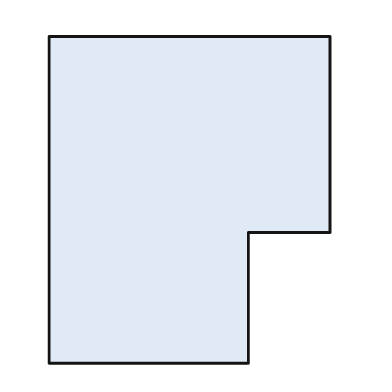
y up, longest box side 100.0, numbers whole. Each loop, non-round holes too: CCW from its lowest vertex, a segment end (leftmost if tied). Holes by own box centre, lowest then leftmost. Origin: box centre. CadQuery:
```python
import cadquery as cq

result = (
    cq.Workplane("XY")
    .moveTo(-43.0, -50.0)
    .lineTo(18.0, -50.0)
    .lineTo(18.0, -10.0)
    .lineTo(43.0, -10.0)
    .lineTo(43.0, 50.0)
    .lineTo(-43.0, 50.0)
    .close()
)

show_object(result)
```